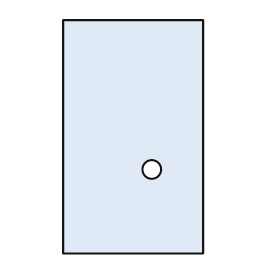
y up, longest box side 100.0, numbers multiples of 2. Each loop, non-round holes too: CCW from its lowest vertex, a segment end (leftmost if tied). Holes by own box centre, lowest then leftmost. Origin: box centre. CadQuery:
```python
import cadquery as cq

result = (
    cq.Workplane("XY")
    .moveTo(-30.0, -50.0)
    .lineTo(30.0, -50.0)
    .lineTo(30.0, 50.0)
    .lineTo(-30.0, 50.0)
    .close()
    .moveTo(8.0, -14.0)
    .circle(4.0)
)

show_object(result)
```